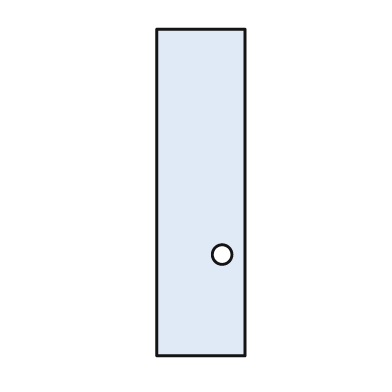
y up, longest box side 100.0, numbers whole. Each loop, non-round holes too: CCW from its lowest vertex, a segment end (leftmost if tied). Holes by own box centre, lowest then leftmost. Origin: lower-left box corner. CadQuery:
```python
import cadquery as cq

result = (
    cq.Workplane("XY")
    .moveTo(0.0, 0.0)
    .lineTo(27.0, 0.0)
    .lineTo(27.0, 100.0)
    .lineTo(0.0, 100.0)
    .close()
    .moveTo(20.0, 31.0)
    .circle(3.0)
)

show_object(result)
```